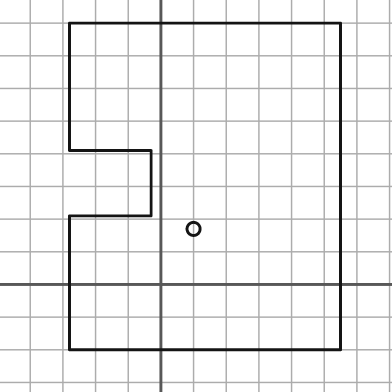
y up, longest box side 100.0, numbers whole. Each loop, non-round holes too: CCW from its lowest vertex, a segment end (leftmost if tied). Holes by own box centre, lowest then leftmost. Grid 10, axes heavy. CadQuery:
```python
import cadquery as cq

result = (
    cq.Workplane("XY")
    .moveTo(-28.0, -20.0)
    .lineTo(55.0, -20.0)
    .lineTo(55.0, 80.0)
    .lineTo(-28.0, 80.0)
    .lineTo(-28.0, 41.0)
    .lineTo(-3.0, 41.0)
    .lineTo(-3.0, 21.0)
    .lineTo(-28.0, 21.0)
    .close()
    .moveTo(10.0, 17.0)
    .circle(2.0)
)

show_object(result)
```